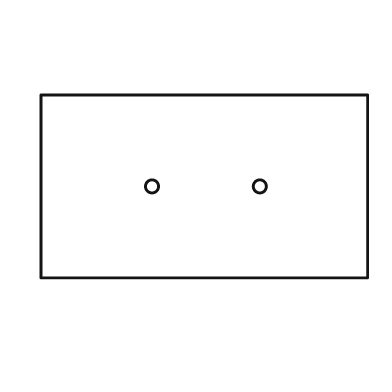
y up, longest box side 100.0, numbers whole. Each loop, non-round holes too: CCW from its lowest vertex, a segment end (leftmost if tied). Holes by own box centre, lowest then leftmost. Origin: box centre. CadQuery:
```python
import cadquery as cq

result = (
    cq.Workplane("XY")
    .moveTo(-50.0, -28.0)
    .lineTo(50.0, -28.0)
    .lineTo(50.0, 28.0)
    .lineTo(-50.0, 28.0)
    .close()
    .moveTo(-16.0, 0.0)
    .circle(2.0)
    .moveTo(17.0, 0.0)
    .circle(2.0)
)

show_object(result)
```